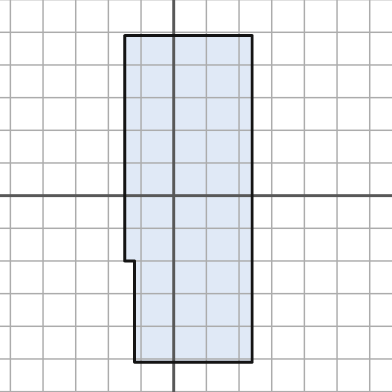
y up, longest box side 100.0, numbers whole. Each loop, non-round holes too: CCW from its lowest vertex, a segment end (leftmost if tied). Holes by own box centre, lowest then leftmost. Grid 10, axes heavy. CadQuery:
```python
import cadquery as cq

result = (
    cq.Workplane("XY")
    .moveTo(-12.0, -51.0)
    .lineTo(24.0, -51.0)
    .lineTo(24.0, 49.0)
    .lineTo(-15.0, 49.0)
    .lineTo(-15.0, -20.0)
    .lineTo(-12.0, -20.0)
    .close()
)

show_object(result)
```